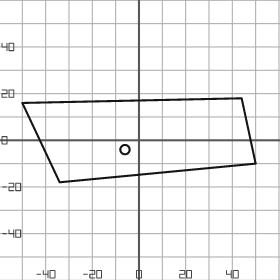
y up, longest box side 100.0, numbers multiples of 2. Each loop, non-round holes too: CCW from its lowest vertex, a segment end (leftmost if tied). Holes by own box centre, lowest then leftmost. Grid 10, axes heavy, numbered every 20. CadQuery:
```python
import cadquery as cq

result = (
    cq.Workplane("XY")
    .moveTo(-34.0, -18.0)
    .lineTo(50.0, -10.0)
    .lineTo(44.0, 18.0)
    .lineTo(-50.0, 16.0)
    .close()
    .moveTo(-6.0, -4.0)
    .circle(2.0)
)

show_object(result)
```